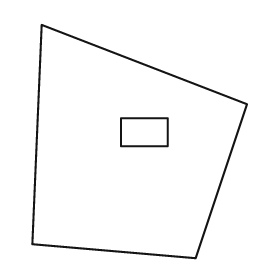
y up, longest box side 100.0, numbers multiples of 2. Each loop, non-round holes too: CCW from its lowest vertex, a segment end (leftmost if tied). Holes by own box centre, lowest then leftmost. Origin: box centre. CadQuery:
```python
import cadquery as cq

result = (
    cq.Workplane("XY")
    .moveTo(24.0, -50.0)
    .lineTo(46.0, 16.0)
    .lineTo(-42.0, 50.0)
    .lineTo(-46.0, -44.0)
    .close()
    .moveTo(-8.0, -2.0)
    .lineTo(12.0, -2.0)
    .lineTo(12.0, 10.0)
    .lineTo(-8.0, 10.0)
    .close()
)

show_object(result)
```